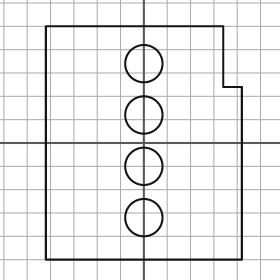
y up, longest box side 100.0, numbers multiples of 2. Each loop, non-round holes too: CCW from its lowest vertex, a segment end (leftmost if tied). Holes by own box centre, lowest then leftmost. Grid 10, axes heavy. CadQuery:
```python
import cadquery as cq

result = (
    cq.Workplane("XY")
    .moveTo(-42.0, -50.0)
    .lineTo(42.0, -50.0)
    .lineTo(42.0, 24.0)
    .lineTo(34.0, 24.0)
    .lineTo(34.0, 50.0)
    .lineTo(-42.0, 50.0)
    .close()
    .moveTo(0.0, -32.0)
    .circle(8.0)
    .moveTo(0.0, -10.0)
    .circle(8.0)
    .moveTo(0.0, 12.0)
    .circle(8.0)
    .moveTo(0.0, 34.0)
    .circle(8.0)
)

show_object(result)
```